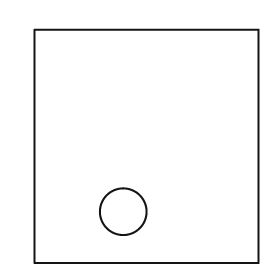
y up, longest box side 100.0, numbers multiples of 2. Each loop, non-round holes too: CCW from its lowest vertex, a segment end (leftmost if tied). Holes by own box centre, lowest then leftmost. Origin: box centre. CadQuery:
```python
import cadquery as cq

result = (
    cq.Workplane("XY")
    .moveTo(-48.0, -50.0)
    .lineTo(48.0, -50.0)
    .lineTo(48.0, 50.0)
    .lineTo(-48.0, 50.0)
    .close()
    .moveTo(-10.0, -28.0)
    .circle(10.0)
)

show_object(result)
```